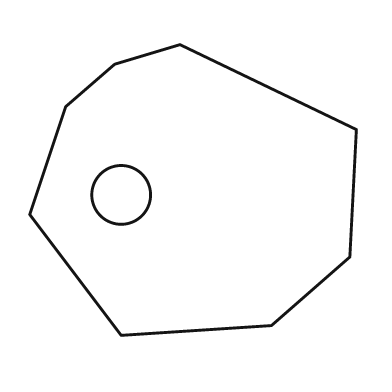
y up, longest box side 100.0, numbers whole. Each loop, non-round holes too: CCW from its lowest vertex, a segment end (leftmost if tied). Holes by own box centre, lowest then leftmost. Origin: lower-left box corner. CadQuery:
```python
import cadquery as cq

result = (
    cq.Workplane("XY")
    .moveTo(28.0, 0.0)
    .lineTo(74.0, 3.0)
    .lineTo(98.0, 24.0)
    .lineTo(100.0, 63.0)
    .lineTo(46.0, 89.0)
    .lineTo(26.0, 83.0)
    .lineTo(11.0, 70.0)
    .lineTo(0.0, 37.0)
    .close()
    .moveTo(28.0, 43.0)
    .circle(9.0)
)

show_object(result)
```